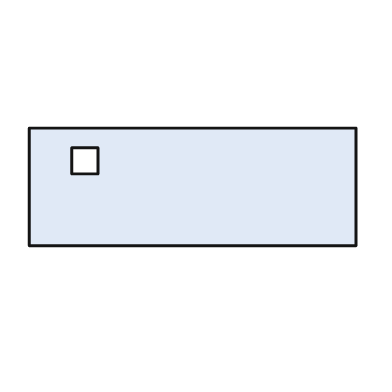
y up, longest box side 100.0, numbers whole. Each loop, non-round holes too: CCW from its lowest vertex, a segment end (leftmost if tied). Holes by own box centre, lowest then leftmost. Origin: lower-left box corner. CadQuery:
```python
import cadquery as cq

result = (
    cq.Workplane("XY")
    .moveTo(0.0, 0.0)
    .lineTo(100.0, 0.0)
    .lineTo(100.0, 36.0)
    .lineTo(0.0, 36.0)
    .close()
    .moveTo(13.0, 22.0)
    .lineTo(21.0, 22.0)
    .lineTo(21.0, 30.0)
    .lineTo(13.0, 30.0)
    .close()
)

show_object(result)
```